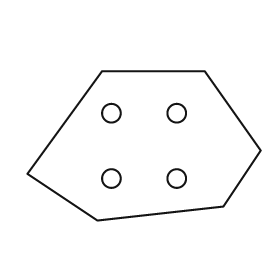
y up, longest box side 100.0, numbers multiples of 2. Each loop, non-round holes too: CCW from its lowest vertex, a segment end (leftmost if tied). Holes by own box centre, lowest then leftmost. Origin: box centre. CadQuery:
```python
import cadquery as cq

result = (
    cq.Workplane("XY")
    .moveTo(-20.0, -32.0)
    .lineTo(34.0, -26.0)
    .lineTo(50.0, -2.0)
    .lineTo(26.0, 32.0)
    .lineTo(-18.0, 32.0)
    .lineTo(-50.0, -12.0)
    .close()
    .moveTo(-14.0, -14.0)
    .circle(4.0)
    .moveTo(14.0, -14.0)
    .circle(4.0)
    .moveTo(-14.0, 14.0)
    .circle(4.0)
    .moveTo(14.0, 14.0)
    .circle(4.0)
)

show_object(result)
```